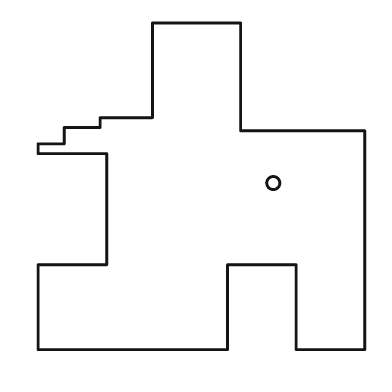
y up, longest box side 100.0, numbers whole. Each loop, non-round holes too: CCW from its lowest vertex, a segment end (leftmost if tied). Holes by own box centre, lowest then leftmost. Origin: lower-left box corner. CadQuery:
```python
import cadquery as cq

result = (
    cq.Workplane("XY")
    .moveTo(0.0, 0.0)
    .lineTo(58.0, 0.0)
    .lineTo(58.0, 26.0)
    .lineTo(79.0, 26.0)
    .lineTo(79.0, 0.0)
    .lineTo(100.0, 0.0)
    .lineTo(100.0, 67.0)
    .lineTo(62.0, 67.0)
    .lineTo(62.0, 100.0)
    .lineTo(35.0, 100.0)
    .lineTo(35.0, 71.0)
    .lineTo(19.0, 71.0)
    .lineTo(19.0, 68.0)
    .lineTo(8.0, 68.0)
    .lineTo(8.0, 63.0)
    .lineTo(0.0, 63.0)
    .lineTo(0.0, 60.0)
    .lineTo(21.0, 60.0)
    .lineTo(21.0, 26.0)
    .lineTo(0.0, 26.0)
    .close()
    .moveTo(72.0, 51.0)
    .circle(2.0)
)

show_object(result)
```